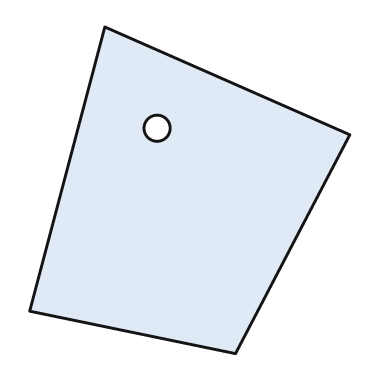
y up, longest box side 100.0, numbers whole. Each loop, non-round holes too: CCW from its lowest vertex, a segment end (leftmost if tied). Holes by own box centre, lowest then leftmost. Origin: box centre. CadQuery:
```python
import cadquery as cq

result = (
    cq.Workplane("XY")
    .moveTo(14.0, -50.0)
    .lineTo(49.0, 17.0)
    .lineTo(-26.0, 50.0)
    .lineTo(-49.0, -37.0)
    .close()
    .moveTo(-10.0, 19.0)
    .circle(4.0)
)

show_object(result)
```